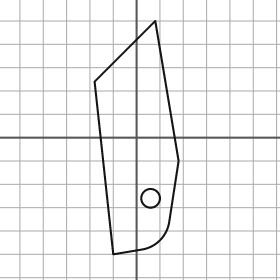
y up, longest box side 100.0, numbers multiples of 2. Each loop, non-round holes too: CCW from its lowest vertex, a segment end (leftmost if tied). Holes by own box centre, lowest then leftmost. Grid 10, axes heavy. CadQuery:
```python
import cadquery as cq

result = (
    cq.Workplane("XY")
    .moveTo(-10.0, -50.0)
    .lineTo(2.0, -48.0)
    .threePointArc((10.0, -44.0), (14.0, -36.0))
    .lineTo(18.0, -10.0)
    .lineTo(8.0, 50.0)
    .lineTo(-18.0, 24.0)
    .close()
    .moveTo(6.0, -26.0)
    .circle(4.0)
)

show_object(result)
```